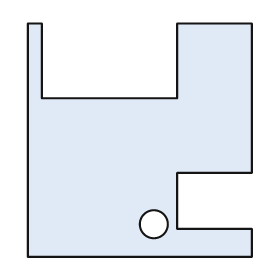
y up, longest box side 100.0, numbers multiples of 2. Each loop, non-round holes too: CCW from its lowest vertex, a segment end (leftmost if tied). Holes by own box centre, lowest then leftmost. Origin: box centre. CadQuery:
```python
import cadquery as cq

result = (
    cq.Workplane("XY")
    .moveTo(-48.0, -50.0)
    .lineTo(48.0, -50.0)
    .lineTo(48.0, -38.0)
    .lineTo(16.0, -38.0)
    .lineTo(16.0, -14.0)
    .lineTo(48.0, -14.0)
    .lineTo(48.0, 50.0)
    .lineTo(16.0, 50.0)
    .lineTo(16.0, 18.0)
    .lineTo(-42.0, 18.0)
    .lineTo(-42.0, 50.0)
    .lineTo(-48.0, 50.0)
    .close()
    .moveTo(6.0, -36.0)
    .circle(6.0)
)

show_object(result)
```